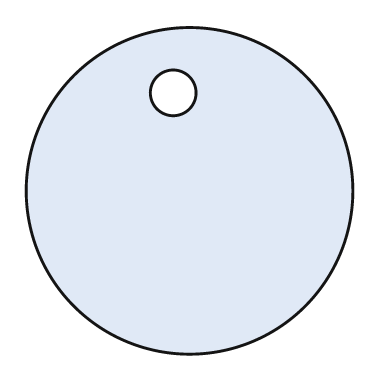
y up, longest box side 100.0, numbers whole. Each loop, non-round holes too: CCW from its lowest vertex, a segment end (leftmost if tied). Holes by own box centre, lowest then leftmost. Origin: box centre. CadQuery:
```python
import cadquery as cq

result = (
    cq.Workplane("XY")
    .moveTo(0.0, 0.0)
    .circle(50.0)
    .moveTo(-5.0, 30.0)
    .circle(7.0)
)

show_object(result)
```